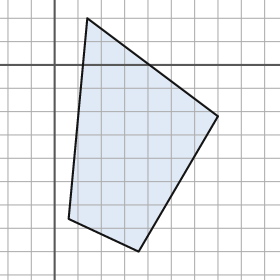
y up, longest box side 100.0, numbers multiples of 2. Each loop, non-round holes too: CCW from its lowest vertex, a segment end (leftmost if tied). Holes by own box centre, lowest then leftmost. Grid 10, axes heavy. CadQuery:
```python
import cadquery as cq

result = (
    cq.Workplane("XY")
    .moveTo(36.0, -80.0)
    .lineTo(70.0, -22.0)
    .lineTo(14.0, 20.0)
    .lineTo(6.0, -66.0)
    .close()
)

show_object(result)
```